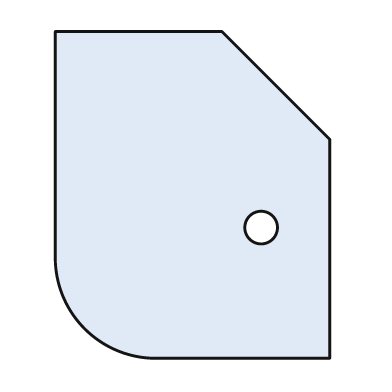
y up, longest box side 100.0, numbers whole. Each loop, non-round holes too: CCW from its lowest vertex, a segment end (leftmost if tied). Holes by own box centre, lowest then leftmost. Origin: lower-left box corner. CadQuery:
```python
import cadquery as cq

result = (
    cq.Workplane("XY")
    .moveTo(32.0, 0.0)
    .lineTo(84.0, 0.0)
    .lineTo(84.0, 67.0)
    .lineTo(51.0, 100.0)
    .lineTo(0.0, 100.0)
    .lineTo(0.0, 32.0)
    .threePointArc((9.0, 9.0), (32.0, 0.0))
    .close()
    .moveTo(63.0, 40.0)
    .circle(5.0)
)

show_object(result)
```